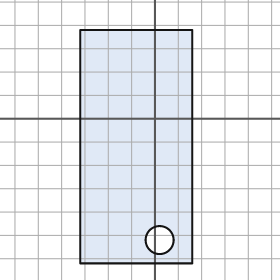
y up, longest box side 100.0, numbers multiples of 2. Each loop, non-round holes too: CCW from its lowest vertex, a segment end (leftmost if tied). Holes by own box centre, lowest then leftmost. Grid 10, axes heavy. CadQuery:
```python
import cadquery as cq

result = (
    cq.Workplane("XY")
    .moveTo(-32.0, -62.0)
    .lineTo(16.0, -62.0)
    .lineTo(16.0, 38.0)
    .lineTo(-32.0, 38.0)
    .close()
    .moveTo(2.0, -52.0)
    .circle(6.0)
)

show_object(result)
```